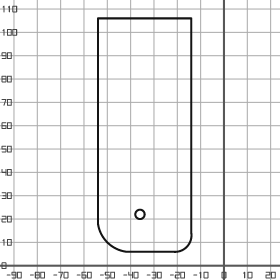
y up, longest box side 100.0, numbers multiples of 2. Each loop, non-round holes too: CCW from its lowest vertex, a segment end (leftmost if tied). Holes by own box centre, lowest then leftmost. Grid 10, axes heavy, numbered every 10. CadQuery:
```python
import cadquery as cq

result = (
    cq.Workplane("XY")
    .moveTo(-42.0, 6.0)
    .lineTo(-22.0, 6.0)
    .threePointArc((-16.0, 8.0), (-14.0, 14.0))
    .lineTo(-14.0, 106.0)
    .lineTo(-54.0, 106.0)
    .lineTo(-54.0, 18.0)
    .threePointArc((-50.0, 10.0), (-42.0, 6.0))
    .close()
    .moveTo(-36.0, 22.0)
    .circle(2.0)
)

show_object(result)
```